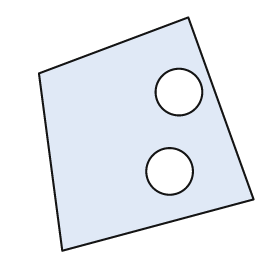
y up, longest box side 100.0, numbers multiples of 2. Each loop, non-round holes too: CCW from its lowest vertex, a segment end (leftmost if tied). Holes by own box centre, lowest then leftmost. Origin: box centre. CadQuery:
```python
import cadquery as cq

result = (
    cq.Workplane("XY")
    .moveTo(-36.0, -50.0)
    .lineTo(46.0, -28.0)
    .lineTo(18.0, 50.0)
    .lineTo(-46.0, 26.0)
    .close()
    .moveTo(10.0, -16.0)
    .circle(10.0)
    .moveTo(14.0, 18.0)
    .circle(10.0)
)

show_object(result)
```